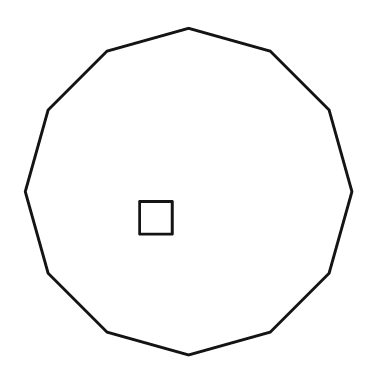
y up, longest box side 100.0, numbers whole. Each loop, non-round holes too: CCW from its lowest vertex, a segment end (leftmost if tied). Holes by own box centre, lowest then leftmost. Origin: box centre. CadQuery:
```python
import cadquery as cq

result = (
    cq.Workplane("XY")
    .moveTo(0.0, -50.0)
    .lineTo(25.0, -43.0)
    .lineTo(43.0, -25.0)
    .lineTo(50.0, 0.0)
    .lineTo(43.0, 25.0)
    .lineTo(25.0, 43.0)
    .lineTo(0.0, 50.0)
    .lineTo(-25.0, 43.0)
    .lineTo(-43.0, 25.0)
    .lineTo(-50.0, 0.0)
    .lineTo(-43.0, -25.0)
    .lineTo(-25.0, -43.0)
    .close()
    .moveTo(-15.0, -13.0)
    .lineTo(-5.0, -13.0)
    .lineTo(-5.0, -3.0)
    .lineTo(-15.0, -3.0)
    .close()
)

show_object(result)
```